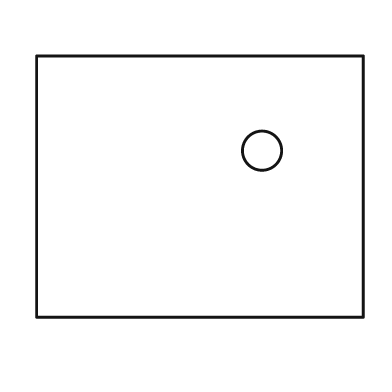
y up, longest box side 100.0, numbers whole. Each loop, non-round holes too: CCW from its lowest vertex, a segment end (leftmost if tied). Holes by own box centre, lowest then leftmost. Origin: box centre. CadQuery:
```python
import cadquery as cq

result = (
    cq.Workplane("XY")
    .moveTo(-50.0, -40.0)
    .lineTo(50.0, -40.0)
    .lineTo(50.0, 40.0)
    .lineTo(-50.0, 40.0)
    .close()
    .moveTo(19.0, 11.0)
    .circle(6.0)
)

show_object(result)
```